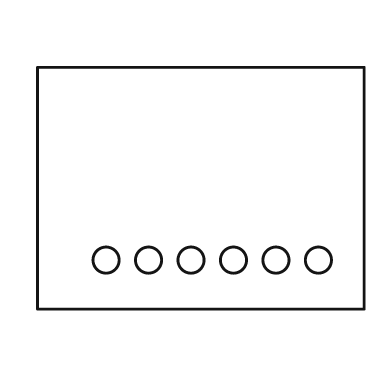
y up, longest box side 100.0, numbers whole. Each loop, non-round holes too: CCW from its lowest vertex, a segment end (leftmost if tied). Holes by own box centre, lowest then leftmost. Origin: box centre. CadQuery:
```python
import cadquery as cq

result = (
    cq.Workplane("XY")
    .moveTo(-50.0, -37.0)
    .lineTo(50.0, -37.0)
    .lineTo(50.0, 37.0)
    .lineTo(-50.0, 37.0)
    .close()
    .moveTo(-29.0, -22.0)
    .circle(4.0)
    .moveTo(-16.0, -22.0)
    .circle(4.0)
    .moveTo(-3.0, -22.0)
    .circle(4.0)
    .moveTo(10.0, -22.0)
    .circle(4.0)
    .moveTo(23.0, -22.0)
    .circle(4.0)
    .moveTo(36.0, -22.0)
    .circle(4.0)
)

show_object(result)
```